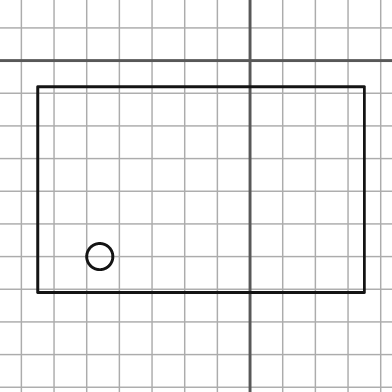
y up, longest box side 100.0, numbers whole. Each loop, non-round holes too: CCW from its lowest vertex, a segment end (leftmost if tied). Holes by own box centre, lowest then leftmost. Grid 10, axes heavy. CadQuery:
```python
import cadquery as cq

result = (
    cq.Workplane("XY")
    .moveTo(-65.0, -71.0)
    .lineTo(35.0, -71.0)
    .lineTo(35.0, -8.0)
    .lineTo(-65.0, -8.0)
    .close()
    .moveTo(-46.0, -60.0)
    .circle(4.0)
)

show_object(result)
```